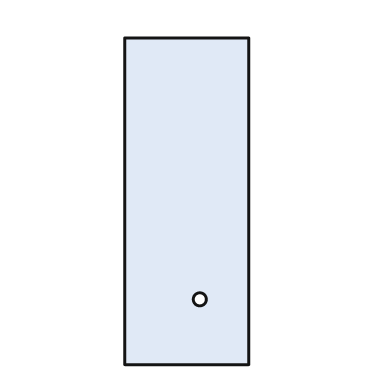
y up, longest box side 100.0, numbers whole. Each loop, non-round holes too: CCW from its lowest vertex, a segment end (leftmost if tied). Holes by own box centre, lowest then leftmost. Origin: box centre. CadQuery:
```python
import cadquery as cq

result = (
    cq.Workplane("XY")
    .moveTo(-19.0, -50.0)
    .lineTo(19.0, -50.0)
    .lineTo(19.0, 50.0)
    .lineTo(-19.0, 50.0)
    .close()
    .moveTo(4.0, -30.0)
    .circle(2.0)
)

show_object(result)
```